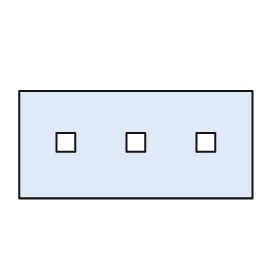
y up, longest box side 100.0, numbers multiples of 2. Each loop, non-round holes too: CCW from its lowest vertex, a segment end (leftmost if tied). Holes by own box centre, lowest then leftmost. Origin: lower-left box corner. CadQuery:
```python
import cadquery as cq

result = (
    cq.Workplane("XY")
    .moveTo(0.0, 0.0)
    .lineTo(100.0, 0.0)
    .lineTo(100.0, 46.0)
    .lineTo(0.0, 46.0)
    .close()
    .moveTo(16.0, 20.0)
    .lineTo(24.0, 20.0)
    .lineTo(24.0, 28.0)
    .lineTo(16.0, 28.0)
    .close()
    .moveTo(46.0, 20.0)
    .lineTo(54.0, 20.0)
    .lineTo(54.0, 28.0)
    .lineTo(46.0, 28.0)
    .close()
    .moveTo(76.0, 20.0)
    .lineTo(84.0, 20.0)
    .lineTo(84.0, 28.0)
    .lineTo(76.0, 28.0)
    .close()
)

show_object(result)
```